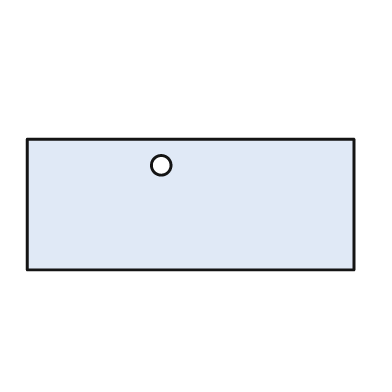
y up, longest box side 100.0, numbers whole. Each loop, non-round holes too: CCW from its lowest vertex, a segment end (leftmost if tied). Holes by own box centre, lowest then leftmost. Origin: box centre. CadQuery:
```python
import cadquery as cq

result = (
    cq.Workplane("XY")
    .moveTo(-50.0, -20.0)
    .lineTo(50.0, -20.0)
    .lineTo(50.0, 20.0)
    .lineTo(-50.0, 20.0)
    .close()
    .moveTo(-9.0, 12.0)
    .circle(3.0)
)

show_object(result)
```